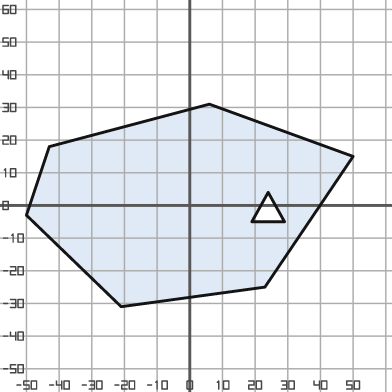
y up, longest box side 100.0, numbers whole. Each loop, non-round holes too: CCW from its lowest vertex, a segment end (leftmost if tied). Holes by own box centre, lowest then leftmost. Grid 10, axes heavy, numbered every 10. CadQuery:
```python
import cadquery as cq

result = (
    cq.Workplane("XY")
    .moveTo(-21.0, -31.0)
    .lineTo(23.0, -25.0)
    .lineTo(50.0, 15.0)
    .lineTo(6.0, 31.0)
    .lineTo(-43.0, 18.0)
    .lineTo(-50.0, -3.0)
    .close()
    .moveTo(19.0, -5.0)
    .lineTo(29.0, -5.0)
    .lineTo(24.0, 4.0)
    .close()
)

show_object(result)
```